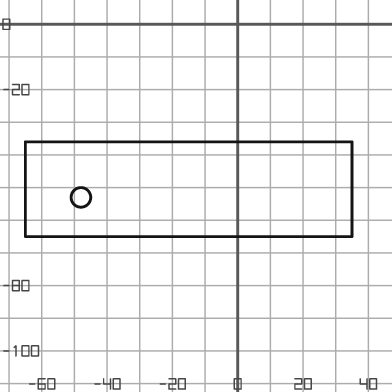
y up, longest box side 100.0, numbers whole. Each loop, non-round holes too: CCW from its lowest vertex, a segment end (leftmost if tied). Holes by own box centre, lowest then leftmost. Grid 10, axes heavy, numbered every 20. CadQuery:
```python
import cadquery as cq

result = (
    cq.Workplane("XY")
    .moveTo(-65.0, -65.0)
    .lineTo(35.0, -65.0)
    .lineTo(35.0, -36.0)
    .lineTo(-65.0, -36.0)
    .close()
    .moveTo(-48.0, -53.0)
    .circle(3.0)
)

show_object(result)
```